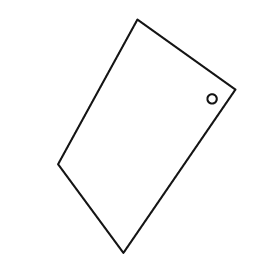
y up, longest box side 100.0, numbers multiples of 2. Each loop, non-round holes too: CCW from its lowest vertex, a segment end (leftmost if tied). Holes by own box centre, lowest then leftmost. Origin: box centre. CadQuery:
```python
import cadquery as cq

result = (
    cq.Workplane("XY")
    .moveTo(-10.0, -50.0)
    .lineTo(38.0, 20.0)
    .lineTo(-4.0, 50.0)
    .lineTo(-38.0, -12.0)
    .close()
    .moveTo(28.0, 16.0)
    .circle(2.0)
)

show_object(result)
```